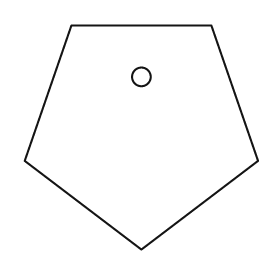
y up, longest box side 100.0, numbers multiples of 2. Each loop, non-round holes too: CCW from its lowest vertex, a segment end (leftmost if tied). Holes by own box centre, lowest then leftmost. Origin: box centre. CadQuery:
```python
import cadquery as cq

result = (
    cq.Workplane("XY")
    .moveTo(0.0, -48.0)
    .lineTo(50.0, -10.0)
    .lineTo(30.0, 48.0)
    .lineTo(-30.0, 48.0)
    .lineTo(-50.0, -10.0)
    .close()
    .moveTo(0.0, 26.0)
    .circle(4.0)
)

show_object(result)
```